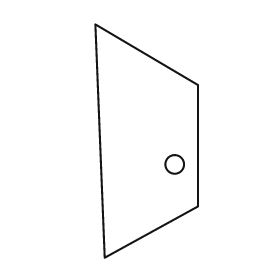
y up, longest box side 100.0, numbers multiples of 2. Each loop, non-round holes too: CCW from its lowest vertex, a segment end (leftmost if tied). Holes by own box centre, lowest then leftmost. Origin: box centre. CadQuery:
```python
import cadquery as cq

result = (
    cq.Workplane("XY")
    .moveTo(-18.0, -50.0)
    .lineTo(22.0, -28.0)
    .lineTo(22.0, 24.0)
    .lineTo(-22.0, 50.0)
    .close()
    .moveTo(12.0, -10.0)
    .circle(4.0)
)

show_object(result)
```